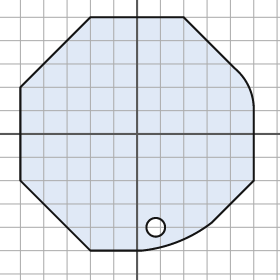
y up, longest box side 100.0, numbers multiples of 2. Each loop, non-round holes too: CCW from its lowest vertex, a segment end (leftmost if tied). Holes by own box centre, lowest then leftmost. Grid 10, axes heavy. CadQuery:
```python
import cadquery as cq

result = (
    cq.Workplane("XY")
    .moveTo(-20.0, -50.0)
    .lineTo(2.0, -50.0)
    .threePointArc((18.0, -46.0), (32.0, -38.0))
    .lineTo(50.0, -20.0)
    .lineTo(50.0, 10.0)
    .threePointArc((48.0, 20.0), (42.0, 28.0))
    .lineTo(20.0, 50.0)
    .lineTo(-20.0, 50.0)
    .lineTo(-50.0, 20.0)
    .lineTo(-50.0, -20.0)
    .close()
    .moveTo(8.0, -40.0)
    .circle(4.0)
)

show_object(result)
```